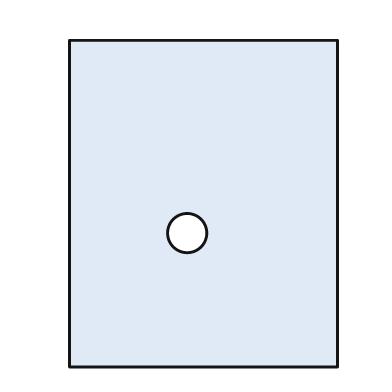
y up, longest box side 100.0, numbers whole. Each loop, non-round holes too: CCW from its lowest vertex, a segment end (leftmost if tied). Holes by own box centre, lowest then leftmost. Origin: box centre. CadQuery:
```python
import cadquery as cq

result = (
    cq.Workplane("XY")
    .moveTo(-41.0, -50.0)
    .lineTo(41.0, -50.0)
    .lineTo(41.0, 50.0)
    .lineTo(-41.0, 50.0)
    .close()
    .moveTo(-5.0, -9.0)
    .circle(6.0)
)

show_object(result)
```